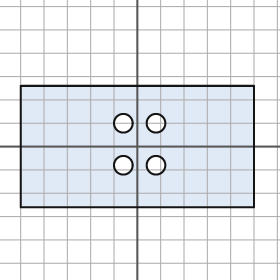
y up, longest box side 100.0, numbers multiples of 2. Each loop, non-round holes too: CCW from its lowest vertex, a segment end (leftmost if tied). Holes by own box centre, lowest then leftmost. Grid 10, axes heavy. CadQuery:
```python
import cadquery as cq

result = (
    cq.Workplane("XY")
    .moveTo(-50.0, -26.0)
    .lineTo(50.0, -26.0)
    .lineTo(50.0, 26.0)
    .lineTo(-50.0, 26.0)
    .close()
    .moveTo(-6.0, -8.0)
    .circle(4.0)
    .moveTo(8.0, -8.0)
    .circle(4.0)
    .moveTo(-6.0, 10.0)
    .circle(4.0)
    .moveTo(8.0, 10.0)
    .circle(4.0)
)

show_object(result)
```